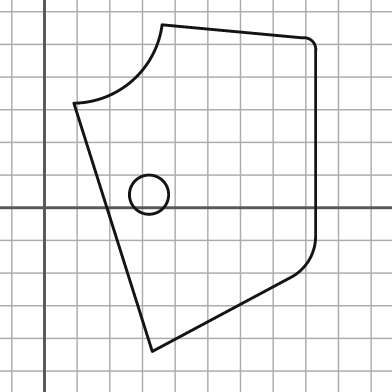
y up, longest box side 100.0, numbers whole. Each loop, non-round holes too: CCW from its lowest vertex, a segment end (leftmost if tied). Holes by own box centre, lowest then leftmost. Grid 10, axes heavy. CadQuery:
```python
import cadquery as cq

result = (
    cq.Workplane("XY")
    .moveTo(33.0, -44.0)
    .lineTo(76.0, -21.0)
    .threePointArc((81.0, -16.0), (83.0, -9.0))
    .lineTo(83.0, 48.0)
    .threePointArc((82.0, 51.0), (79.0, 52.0))
    .lineTo(36.0, 56.0)
    .threePointArc((27.0, 39.0), (9.0, 32.0))
    .close()
    .moveTo(32.0, 4.0)
    .circle(6.0)
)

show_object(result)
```